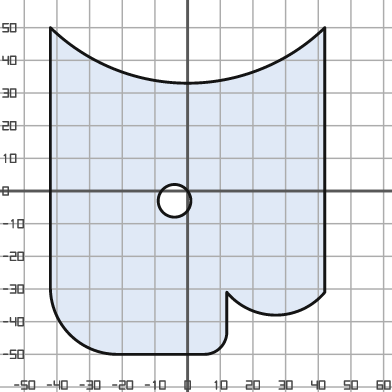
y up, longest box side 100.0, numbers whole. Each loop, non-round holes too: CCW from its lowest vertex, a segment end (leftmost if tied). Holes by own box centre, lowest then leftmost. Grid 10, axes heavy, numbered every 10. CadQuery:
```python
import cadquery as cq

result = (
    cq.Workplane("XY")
    .moveTo(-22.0, -50.0)
    .lineTo(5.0, -50.0)
    .threePointArc((10.0, -48.0), (12.0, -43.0))
    .lineTo(12.0, -31.0)
    .threePointArc((27.0, -38.0), (42.0, -31.0))
    .lineTo(42.0, 50.0)
    .threePointArc((0.0, 33.0), (-42.0, 50.0))
    .lineTo(-42.0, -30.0)
    .threePointArc((-36.0, -44.0), (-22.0, -50.0))
    .close()
    .moveTo(-4.0, -3.0)
    .circle(5.0)
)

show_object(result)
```